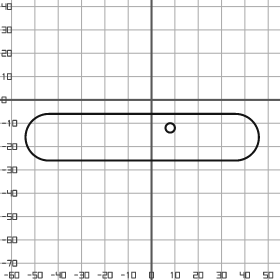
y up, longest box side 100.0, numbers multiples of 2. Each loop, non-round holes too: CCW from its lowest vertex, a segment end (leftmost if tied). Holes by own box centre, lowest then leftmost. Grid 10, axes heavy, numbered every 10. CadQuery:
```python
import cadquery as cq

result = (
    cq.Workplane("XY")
    .moveTo(-44.0, -26.0)
    .lineTo(36.0, -26.0)
    .threePointArc((46.0, -16.0), (36.0, -6.0))
    .lineTo(-44.0, -6.0)
    .threePointArc((-54.0, -16.0), (-44.0, -26.0))
    .close()
    .moveTo(8.0, -12.0)
    .circle(2.0)
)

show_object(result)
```